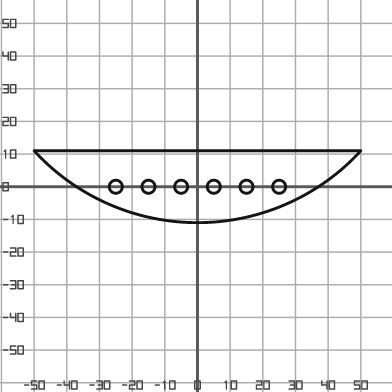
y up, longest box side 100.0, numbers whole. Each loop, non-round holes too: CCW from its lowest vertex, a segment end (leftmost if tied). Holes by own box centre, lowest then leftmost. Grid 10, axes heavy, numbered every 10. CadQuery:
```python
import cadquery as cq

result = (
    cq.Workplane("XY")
    .moveTo(-50.0, 11.0)
    .threePointArc((0.0, -11.0), (50.0, 11.0))
    .close()
    .moveTo(-25.0, 0.0)
    .circle(2.0)
    .moveTo(-15.0, 0.0)
    .circle(2.0)
    .moveTo(-5.0, 0.0)
    .circle(2.0)
    .moveTo(5.0, 0.0)
    .circle(2.0)
    .moveTo(15.0, 0.0)
    .circle(2.0)
    .moveTo(25.0, 0.0)
    .circle(2.0)
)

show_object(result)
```